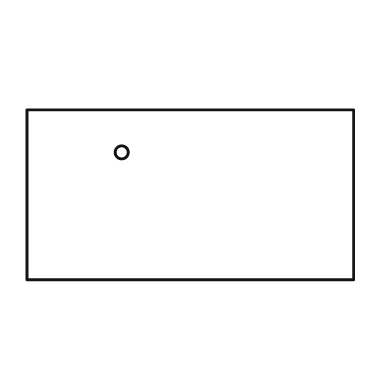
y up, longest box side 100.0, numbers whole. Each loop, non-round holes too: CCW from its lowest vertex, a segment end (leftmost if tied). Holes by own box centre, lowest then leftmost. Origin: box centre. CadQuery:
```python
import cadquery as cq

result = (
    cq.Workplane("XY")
    .moveTo(-50.0, -26.0)
    .lineTo(50.0, -26.0)
    .lineTo(50.0, 26.0)
    .lineTo(-50.0, 26.0)
    .close()
    .moveTo(-21.0, 13.0)
    .circle(2.0)
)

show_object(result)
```